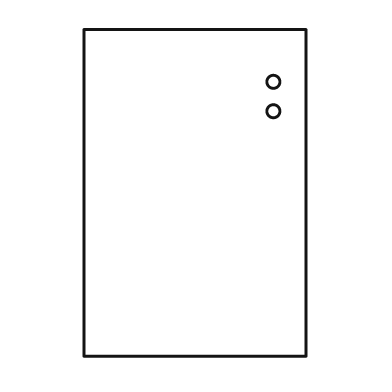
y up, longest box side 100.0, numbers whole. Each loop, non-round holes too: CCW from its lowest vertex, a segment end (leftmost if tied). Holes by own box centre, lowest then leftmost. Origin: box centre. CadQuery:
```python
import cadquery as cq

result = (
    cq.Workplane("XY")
    .moveTo(-34.0, -50.0)
    .lineTo(34.0, -50.0)
    .lineTo(34.0, 50.0)
    .lineTo(-34.0, 50.0)
    .close()
    .moveTo(24.0, 25.0)
    .circle(2.0)
    .moveTo(24.0, 34.0)
    .circle(2.0)
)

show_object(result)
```